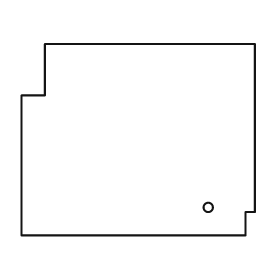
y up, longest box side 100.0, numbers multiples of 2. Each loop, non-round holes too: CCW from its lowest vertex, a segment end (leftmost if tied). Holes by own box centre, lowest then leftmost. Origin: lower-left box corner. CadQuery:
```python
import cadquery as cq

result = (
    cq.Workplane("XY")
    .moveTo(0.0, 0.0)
    .lineTo(96.0, 0.0)
    .lineTo(96.0, 10.0)
    .lineTo(100.0, 10.0)
    .lineTo(100.0, 82.0)
    .lineTo(10.0, 82.0)
    .lineTo(10.0, 60.0)
    .lineTo(0.0, 60.0)
    .close()
    .moveTo(80.0, 12.0)
    .circle(2.0)
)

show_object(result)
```